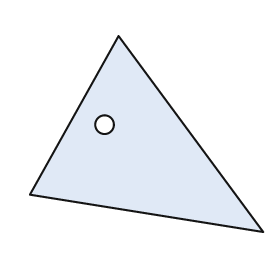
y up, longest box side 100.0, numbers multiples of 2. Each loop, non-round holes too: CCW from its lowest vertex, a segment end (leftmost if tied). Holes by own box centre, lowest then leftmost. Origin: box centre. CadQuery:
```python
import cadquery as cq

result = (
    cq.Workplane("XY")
    .moveTo(50.0, -42.0)
    .lineTo(-12.0, 42.0)
    .lineTo(-50.0, -26.0)
    .close()
    .moveTo(-18.0, 4.0)
    .circle(4.0)
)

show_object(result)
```